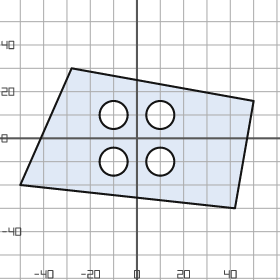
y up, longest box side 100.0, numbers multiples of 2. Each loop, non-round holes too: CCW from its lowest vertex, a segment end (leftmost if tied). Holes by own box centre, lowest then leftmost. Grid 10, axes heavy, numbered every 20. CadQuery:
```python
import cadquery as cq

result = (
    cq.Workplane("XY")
    .moveTo(42.0, -30.0)
    .lineTo(50.0, 16.0)
    .lineTo(-28.0, 30.0)
    .lineTo(-50.0, -20.0)
    .close()
    .moveTo(-10.0, -10.0)
    .circle(6.0)
    .moveTo(10.0, -10.0)
    .circle(6.0)
    .moveTo(-10.0, 10.0)
    .circle(6.0)
    .moveTo(10.0, 10.0)
    .circle(6.0)
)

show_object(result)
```